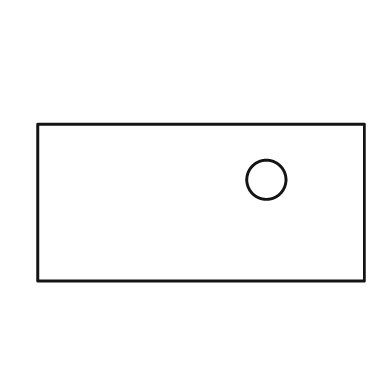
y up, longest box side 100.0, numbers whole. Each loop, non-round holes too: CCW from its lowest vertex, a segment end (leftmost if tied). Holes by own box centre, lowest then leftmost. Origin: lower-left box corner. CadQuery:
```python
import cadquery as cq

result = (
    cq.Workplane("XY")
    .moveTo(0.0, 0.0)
    .lineTo(100.0, 0.0)
    .lineTo(100.0, 48.0)
    .lineTo(0.0, 48.0)
    .close()
    .moveTo(70.0, 31.0)
    .circle(6.0)
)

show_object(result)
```